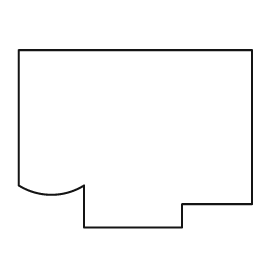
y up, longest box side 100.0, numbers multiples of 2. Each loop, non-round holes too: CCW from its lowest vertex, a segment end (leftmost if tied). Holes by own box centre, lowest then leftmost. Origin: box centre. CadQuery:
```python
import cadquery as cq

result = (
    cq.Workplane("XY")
    .moveTo(-22.0, -38.0)
    .lineTo(20.0, -38.0)
    .lineTo(20.0, -28.0)
    .lineTo(50.0, -28.0)
    .lineTo(50.0, 38.0)
    .lineTo(-50.0, 38.0)
    .lineTo(-50.0, -20.0)
    .threePointArc((-36.0, -24.0), (-22.0, -20.0))
    .close()
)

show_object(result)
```